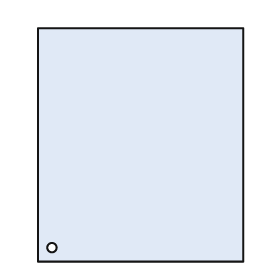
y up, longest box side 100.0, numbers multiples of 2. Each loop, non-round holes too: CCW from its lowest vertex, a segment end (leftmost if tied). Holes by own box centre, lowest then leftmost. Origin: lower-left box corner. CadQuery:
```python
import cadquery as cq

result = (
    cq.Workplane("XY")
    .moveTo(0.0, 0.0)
    .lineTo(88.0, 0.0)
    .lineTo(88.0, 100.0)
    .lineTo(0.0, 100.0)
    .close()
    .moveTo(6.0, 6.0)
    .circle(2.0)
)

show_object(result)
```